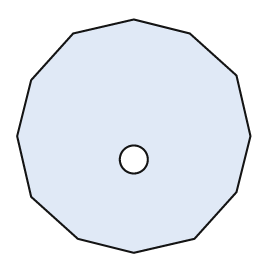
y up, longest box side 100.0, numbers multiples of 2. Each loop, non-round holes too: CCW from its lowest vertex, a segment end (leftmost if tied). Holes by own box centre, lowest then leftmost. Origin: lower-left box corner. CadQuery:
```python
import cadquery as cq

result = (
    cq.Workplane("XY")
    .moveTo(50.0, 0.0)
    .lineTo(76.0, 6.0)
    .lineTo(94.0, 26.0)
    .lineTo(100.0, 50.0)
    .lineTo(94.0, 76.0)
    .lineTo(74.0, 94.0)
    .lineTo(50.0, 100.0)
    .lineTo(24.0, 94.0)
    .lineTo(6.0, 74.0)
    .lineTo(0.0, 50.0)
    .lineTo(6.0, 24.0)
    .lineTo(26.0, 6.0)
    .close()
    .moveTo(50.0, 40.0)
    .circle(6.0)
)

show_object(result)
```